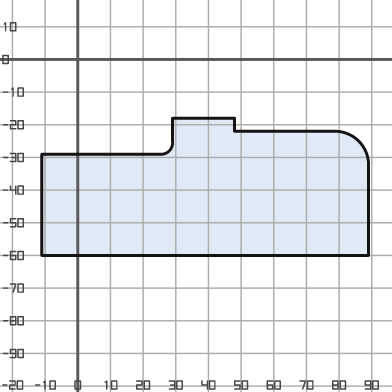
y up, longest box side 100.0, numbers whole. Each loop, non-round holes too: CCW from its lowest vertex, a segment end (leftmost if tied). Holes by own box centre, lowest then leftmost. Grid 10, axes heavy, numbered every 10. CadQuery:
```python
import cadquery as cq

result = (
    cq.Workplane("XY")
    .moveTo(-11.0, -60.0)
    .lineTo(89.0, -60.0)
    .lineTo(89.0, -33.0)
    .threePointArc((86.0, -25.0), (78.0, -22.0))
    .lineTo(48.0, -22.0)
    .lineTo(48.0, -18.0)
    .lineTo(29.0, -18.0)
    .lineTo(29.0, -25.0)
    .threePointArc((28.0, -28.0), (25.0, -29.0))
    .lineTo(-11.0, -29.0)
    .close()
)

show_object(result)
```